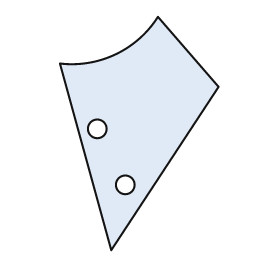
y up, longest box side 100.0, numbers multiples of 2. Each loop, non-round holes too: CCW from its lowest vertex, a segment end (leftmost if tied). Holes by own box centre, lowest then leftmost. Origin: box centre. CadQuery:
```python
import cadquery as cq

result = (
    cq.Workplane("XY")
    .moveTo(-12.0, -50.0)
    .lineTo(34.0, 20.0)
    .lineTo(8.0, 50.0)
    .threePointArc((-10.0, 34.0), (-34.0, 30.0))
    .close()
    .moveTo(-6.0, -22.0)
    .circle(4.0)
    .moveTo(-18.0, 2.0)
    .circle(4.0)
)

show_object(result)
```